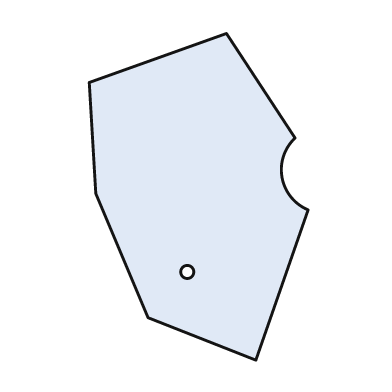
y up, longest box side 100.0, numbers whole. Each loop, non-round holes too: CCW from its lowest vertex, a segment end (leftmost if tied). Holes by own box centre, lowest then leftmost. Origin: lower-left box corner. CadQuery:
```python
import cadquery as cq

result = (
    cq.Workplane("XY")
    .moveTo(51.0, 0.0)
    .lineTo(67.0, 46.0)
    .threePointArc((59.0, 56.0), (63.0, 68.0))
    .lineTo(42.0, 100.0)
    .lineTo(0.0, 85.0)
    .lineTo(2.0, 51.0)
    .lineTo(18.0, 13.0)
    .close()
    .moveTo(30.0, 27.0)
    .circle(2.0)
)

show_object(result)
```